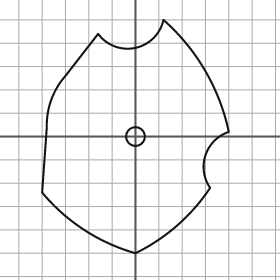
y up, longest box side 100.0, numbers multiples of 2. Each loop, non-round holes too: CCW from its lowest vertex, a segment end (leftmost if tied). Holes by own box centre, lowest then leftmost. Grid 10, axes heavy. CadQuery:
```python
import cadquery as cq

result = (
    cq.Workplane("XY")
    .moveTo(0.0, -50.0)
    .threePointArc((18.0, -38.0), (32.0, -22.0))
    .threePointArc((30.0, -8.0), (40.0, 2.0))
    .threePointArc((30.0, 28.0), (12.0, 50.0))
    .threePointArc((0.0, 38.0), (-16.0, 44.0))
    .lineTo(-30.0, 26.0)
    .threePointArc((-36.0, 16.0), (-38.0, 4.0))
    .lineTo(-40.0, -24.0)
    .threePointArc((-22.0, -40.0), (0.0, -50.0))
    .close()
    .moveTo(0.0, 0.0)
    .circle(4.0)
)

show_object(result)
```